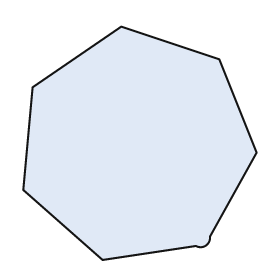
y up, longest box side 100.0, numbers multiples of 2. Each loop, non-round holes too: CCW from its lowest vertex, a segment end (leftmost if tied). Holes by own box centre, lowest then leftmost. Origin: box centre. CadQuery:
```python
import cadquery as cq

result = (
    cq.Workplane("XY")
    .moveTo(-16.0, -50.0)
    .lineTo(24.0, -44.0)
    .threePointArc((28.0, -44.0), (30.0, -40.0))
    .lineTo(50.0, -4.0)
    .lineTo(34.0, 36.0)
    .lineTo(-8.0, 50.0)
    .lineTo(-46.0, 24.0)
    .lineTo(-50.0, -20.0)
    .close()
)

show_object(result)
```